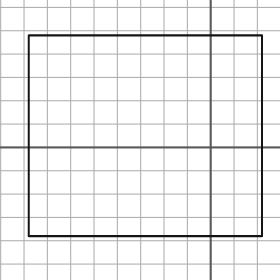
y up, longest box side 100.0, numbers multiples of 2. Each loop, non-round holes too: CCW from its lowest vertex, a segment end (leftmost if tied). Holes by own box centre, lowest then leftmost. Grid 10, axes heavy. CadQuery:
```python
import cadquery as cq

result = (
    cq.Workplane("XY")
    .moveTo(-78.0, -38.0)
    .lineTo(22.0, -38.0)
    .lineTo(22.0, 48.0)
    .lineTo(-78.0, 48.0)
    .close()
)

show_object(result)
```